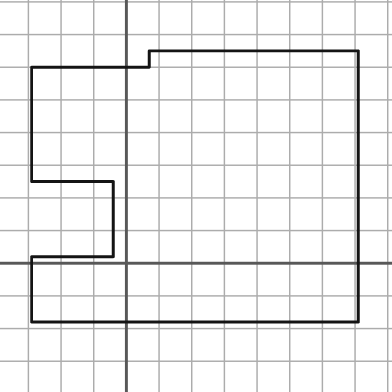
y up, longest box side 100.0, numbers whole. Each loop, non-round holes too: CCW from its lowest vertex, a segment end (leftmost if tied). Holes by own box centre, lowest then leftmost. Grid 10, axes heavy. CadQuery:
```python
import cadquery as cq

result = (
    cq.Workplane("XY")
    .moveTo(-29.0, -18.0)
    .lineTo(71.0, -18.0)
    .lineTo(71.0, 65.0)
    .lineTo(7.0, 65.0)
    .lineTo(7.0, 60.0)
    .lineTo(-29.0, 60.0)
    .lineTo(-29.0, 25.0)
    .lineTo(-4.0, 25.0)
    .lineTo(-4.0, 2.0)
    .lineTo(-29.0, 2.0)
    .close()
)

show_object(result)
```